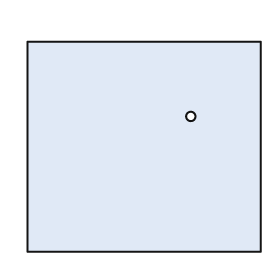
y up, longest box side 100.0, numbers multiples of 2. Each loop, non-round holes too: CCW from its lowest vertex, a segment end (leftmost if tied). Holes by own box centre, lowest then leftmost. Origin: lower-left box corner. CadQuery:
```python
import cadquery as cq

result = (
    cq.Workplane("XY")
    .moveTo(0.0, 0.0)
    .lineTo(100.0, 0.0)
    .lineTo(100.0, 90.0)
    .lineTo(0.0, 90.0)
    .close()
    .moveTo(70.0, 58.0)
    .circle(2.0)
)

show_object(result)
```